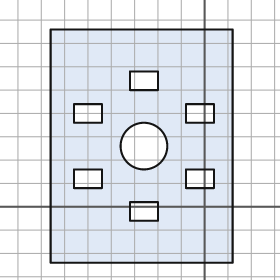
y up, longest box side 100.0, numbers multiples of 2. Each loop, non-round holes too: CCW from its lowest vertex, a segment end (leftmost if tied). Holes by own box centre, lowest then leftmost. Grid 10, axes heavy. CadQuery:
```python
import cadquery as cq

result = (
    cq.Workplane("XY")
    .moveTo(-66.0, -24.0)
    .lineTo(12.0, -24.0)
    .lineTo(12.0, 76.0)
    .lineTo(-66.0, 76.0)
    .close()
    .moveTo(-32.0, -6.0)
    .lineTo(-20.0, -6.0)
    .lineTo(-20.0, 2.0)
    .lineTo(-32.0, 2.0)
    .close()
    .moveTo(-56.0, 8.0)
    .lineTo(-44.0, 8.0)
    .lineTo(-44.0, 16.0)
    .lineTo(-56.0, 16.0)
    .close()
    .moveTo(-8.0, 8.0)
    .lineTo(4.0, 8.0)
    .lineTo(4.0, 16.0)
    .lineTo(-8.0, 16.0)
    .close()
    .moveTo(-26.0, 26.0)
    .circle(10.0)
    .moveTo(-56.0, 36.0)
    .lineTo(-44.0, 36.0)
    .lineTo(-44.0, 44.0)
    .lineTo(-56.0, 44.0)
    .close()
    .moveTo(-8.0, 36.0)
    .lineTo(4.0, 36.0)
    .lineTo(4.0, 44.0)
    .lineTo(-8.0, 44.0)
    .close()
    .moveTo(-32.0, 50.0)
    .lineTo(-20.0, 50.0)
    .lineTo(-20.0, 58.0)
    .lineTo(-32.0, 58.0)
    .close()
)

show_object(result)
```